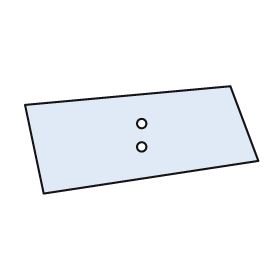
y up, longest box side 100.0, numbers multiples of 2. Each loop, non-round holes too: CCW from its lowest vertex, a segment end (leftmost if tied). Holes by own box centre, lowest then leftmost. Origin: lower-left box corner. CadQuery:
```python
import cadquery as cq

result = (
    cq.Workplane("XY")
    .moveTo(8.0, 0.0)
    .lineTo(100.0, 14.0)
    .lineTo(88.0, 46.0)
    .lineTo(0.0, 38.0)
    .close()
    .moveTo(50.0, 20.0)
    .circle(2.0)
    .moveTo(50.0, 30.0)
    .circle(2.0)
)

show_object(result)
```